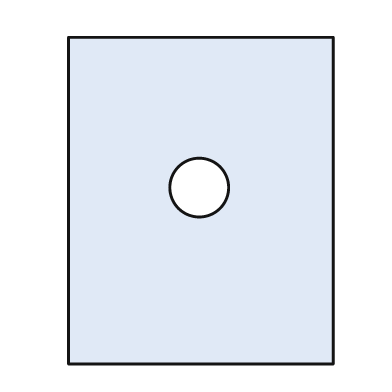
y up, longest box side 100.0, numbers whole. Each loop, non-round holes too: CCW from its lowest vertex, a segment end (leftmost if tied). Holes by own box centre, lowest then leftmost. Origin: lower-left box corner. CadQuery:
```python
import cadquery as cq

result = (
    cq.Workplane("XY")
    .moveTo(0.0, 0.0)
    .lineTo(81.0, 0.0)
    .lineTo(81.0, 100.0)
    .lineTo(0.0, 100.0)
    .close()
    .moveTo(40.0, 54.0)
    .circle(9.0)
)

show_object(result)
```